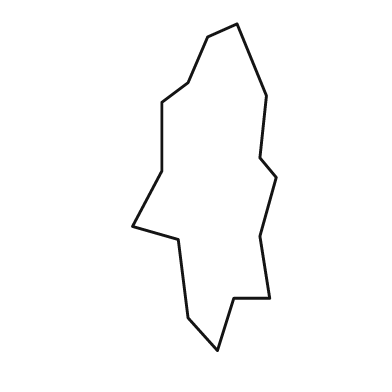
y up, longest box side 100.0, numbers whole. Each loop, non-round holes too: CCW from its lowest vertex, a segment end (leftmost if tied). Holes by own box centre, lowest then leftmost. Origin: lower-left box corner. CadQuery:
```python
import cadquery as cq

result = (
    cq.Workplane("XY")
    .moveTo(26.0, 0.0)
    .lineTo(31.0, 16.0)
    .lineTo(42.0, 16.0)
    .lineTo(39.0, 35.0)
    .lineTo(44.0, 53.0)
    .lineTo(39.0, 59.0)
    .lineTo(41.0, 78.0)
    .lineTo(32.0, 100.0)
    .lineTo(23.0, 96.0)
    .lineTo(17.0, 82.0)
    .lineTo(9.0, 76.0)
    .lineTo(9.0, 55.0)
    .lineTo(0.0, 38.0)
    .lineTo(14.0, 34.0)
    .lineTo(17.0, 10.0)
    .close()
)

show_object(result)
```